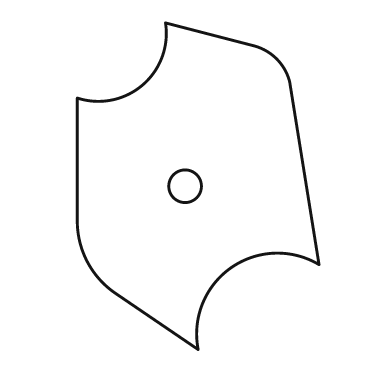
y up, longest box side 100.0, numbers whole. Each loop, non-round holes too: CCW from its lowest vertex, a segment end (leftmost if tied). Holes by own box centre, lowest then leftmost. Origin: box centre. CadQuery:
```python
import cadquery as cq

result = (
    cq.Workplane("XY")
    .moveTo(0.0, -50.0)
    .threePointArc((10.0, -25.0), (37.0, -24.0))
    .lineTo(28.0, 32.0)
    .threePointArc((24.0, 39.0), (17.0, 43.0))
    .lineTo(-10.0, 50.0)
    .threePointArc((-17.0, 31.0), (-37.0, 27.0))
    .lineTo(-37.0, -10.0)
    .threePointArc((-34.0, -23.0), (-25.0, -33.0))
    .close()
    .moveTo(-4.0, 0.0)
    .circle(5.0)
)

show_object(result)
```